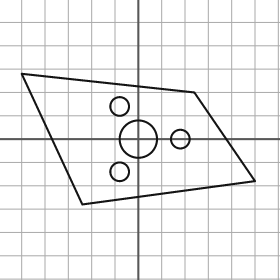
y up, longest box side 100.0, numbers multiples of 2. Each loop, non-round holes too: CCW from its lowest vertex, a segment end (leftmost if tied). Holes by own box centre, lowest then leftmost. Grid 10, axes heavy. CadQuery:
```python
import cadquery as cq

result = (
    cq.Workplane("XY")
    .moveTo(-24.0, -28.0)
    .lineTo(50.0, -18.0)
    .lineTo(24.0, 20.0)
    .lineTo(-50.0, 28.0)
    .close()
    .moveTo(-8.0, -14.0)
    .circle(4.0)
    .moveTo(0.0, 0.0)
    .circle(8.0)
    .moveTo(18.0, 0.0)
    .circle(4.0)
    .moveTo(-8.0, 14.0)
    .circle(4.0)
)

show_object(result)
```